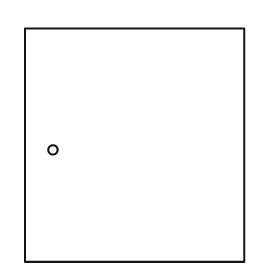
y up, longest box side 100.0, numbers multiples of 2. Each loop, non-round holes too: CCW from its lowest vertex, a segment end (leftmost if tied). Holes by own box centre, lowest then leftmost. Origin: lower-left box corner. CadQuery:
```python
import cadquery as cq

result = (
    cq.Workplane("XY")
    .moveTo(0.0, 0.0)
    .lineTo(94.0, 0.0)
    .lineTo(94.0, 100.0)
    .lineTo(0.0, 100.0)
    .close()
    .moveTo(12.0, 48.0)
    .circle(2.0)
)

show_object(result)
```